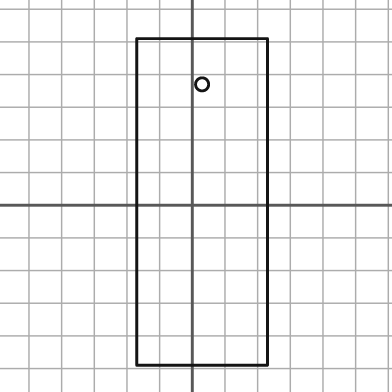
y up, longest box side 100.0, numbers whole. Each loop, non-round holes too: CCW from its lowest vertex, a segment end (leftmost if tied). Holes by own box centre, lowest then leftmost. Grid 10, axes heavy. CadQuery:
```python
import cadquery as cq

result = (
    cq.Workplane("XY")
    .moveTo(-17.0, -49.0)
    .lineTo(23.0, -49.0)
    .lineTo(23.0, 51.0)
    .lineTo(-17.0, 51.0)
    .close()
    .moveTo(3.0, 37.0)
    .circle(2.0)
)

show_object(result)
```